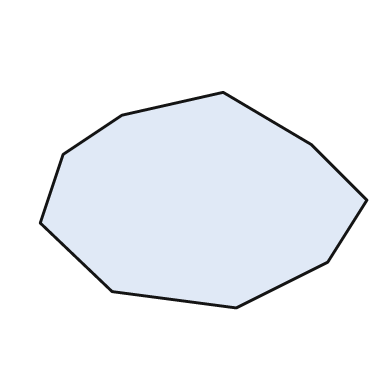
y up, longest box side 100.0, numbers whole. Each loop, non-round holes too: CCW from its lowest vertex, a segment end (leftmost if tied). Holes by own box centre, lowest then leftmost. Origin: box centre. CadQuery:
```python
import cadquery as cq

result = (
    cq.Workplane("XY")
    .moveTo(10.0, -33.0)
    .lineTo(38.0, -19.0)
    .lineTo(50.0, 0.0)
    .lineTo(33.0, 17.0)
    .lineTo(6.0, 33.0)
    .lineTo(-25.0, 26.0)
    .lineTo(-43.0, 14.0)
    .lineTo(-50.0, -7.0)
    .lineTo(-28.0, -28.0)
    .close()
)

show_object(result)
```